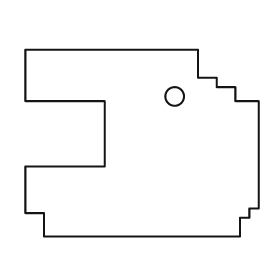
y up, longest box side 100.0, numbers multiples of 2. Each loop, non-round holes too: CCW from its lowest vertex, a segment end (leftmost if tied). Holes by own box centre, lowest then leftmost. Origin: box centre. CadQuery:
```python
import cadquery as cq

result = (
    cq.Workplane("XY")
    .moveTo(-42.0, -40.0)
    .lineTo(42.0, -40.0)
    .lineTo(42.0, -32.0)
    .lineTo(46.0, -32.0)
    .lineTo(46.0, -28.0)
    .lineTo(50.0, -28.0)
    .lineTo(50.0, 18.0)
    .lineTo(40.0, 18.0)
    .lineTo(40.0, 24.0)
    .lineTo(32.0, 24.0)
    .lineTo(32.0, 28.0)
    .lineTo(24.0, 28.0)
    .lineTo(24.0, 40.0)
    .lineTo(-50.0, 40.0)
    .lineTo(-50.0, 18.0)
    .lineTo(-16.0, 18.0)
    .lineTo(-16.0, -10.0)
    .lineTo(-50.0, -10.0)
    .lineTo(-50.0, -30.0)
    .lineTo(-42.0, -30.0)
    .close()
    .moveTo(14.0, 20.0)
    .circle(4.0)
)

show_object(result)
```